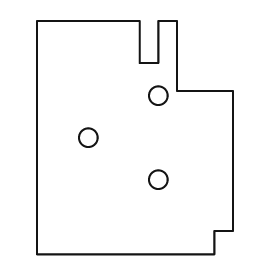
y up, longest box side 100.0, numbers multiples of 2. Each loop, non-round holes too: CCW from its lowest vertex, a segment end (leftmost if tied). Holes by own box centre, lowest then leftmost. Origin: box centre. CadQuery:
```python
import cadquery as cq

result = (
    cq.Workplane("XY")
    .moveTo(-42.0, -50.0)
    .lineTo(34.0, -50.0)
    .lineTo(34.0, -40.0)
    .lineTo(42.0, -40.0)
    .lineTo(42.0, 20.0)
    .lineTo(18.0, 20.0)
    .lineTo(18.0, 50.0)
    .lineTo(10.0, 50.0)
    .lineTo(10.0, 32.0)
    .lineTo(2.0, 32.0)
    .lineTo(2.0, 50.0)
    .lineTo(-42.0, 50.0)
    .close()
    .moveTo(10.0, -18.0)
    .circle(4.0)
    .moveTo(-20.0, 0.0)
    .circle(4.0)
    .moveTo(10.0, 18.0)
    .circle(4.0)
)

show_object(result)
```